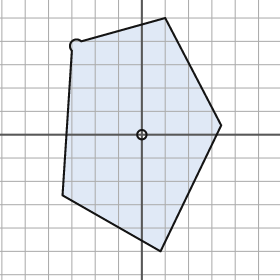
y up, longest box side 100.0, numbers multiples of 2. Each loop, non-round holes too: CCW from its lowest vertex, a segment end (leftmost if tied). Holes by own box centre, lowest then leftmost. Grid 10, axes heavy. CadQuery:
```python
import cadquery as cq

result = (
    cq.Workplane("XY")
    .moveTo(8.0, -50.0)
    .lineTo(34.0, 4.0)
    .lineTo(10.0, 50.0)
    .lineTo(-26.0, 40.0)
    .threePointArc((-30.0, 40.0), (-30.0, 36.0))
    .lineTo(-34.0, -26.0)
    .close()
    .moveTo(0.0, 0.0)
    .circle(2.0)
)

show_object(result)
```